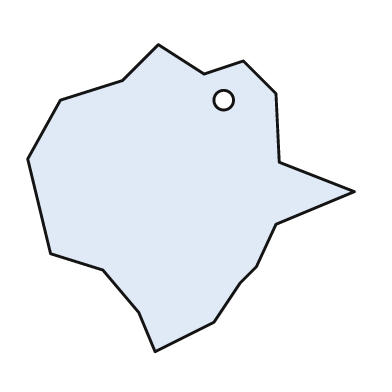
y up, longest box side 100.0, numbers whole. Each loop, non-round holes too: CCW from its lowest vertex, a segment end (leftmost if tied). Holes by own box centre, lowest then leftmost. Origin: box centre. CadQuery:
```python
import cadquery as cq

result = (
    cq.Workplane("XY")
    .moveTo(-11.0, -47.0)
    .lineTo(7.0, -38.0)
    .lineTo(15.0, -26.0)
    .lineTo(20.0, -21.0)
    .lineTo(26.0, -8.0)
    .lineTo(50.0, 2.0)
    .lineTo(27.0, 11.0)
    .lineTo(26.0, 32.0)
    .lineTo(16.0, 42.0)
    .lineTo(4.0, 38.0)
    .lineTo(-10.0, 47.0)
    .lineTo(-21.0, 36.0)
    .lineTo(-40.0, 30.0)
    .lineTo(-50.0, 12.0)
    .lineTo(-43.0, -17.0)
    .lineTo(-27.0, -22.0)
    .lineTo(-16.0, -35.0)
    .close()
    .moveTo(10.0, 30.0)
    .circle(3.0)
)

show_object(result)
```